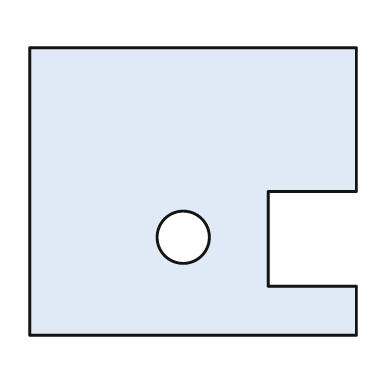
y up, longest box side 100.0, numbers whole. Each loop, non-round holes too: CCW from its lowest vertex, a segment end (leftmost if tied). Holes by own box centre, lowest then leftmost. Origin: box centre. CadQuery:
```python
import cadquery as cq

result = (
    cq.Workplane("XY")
    .moveTo(-50.0, -44.0)
    .lineTo(50.0, -44.0)
    .lineTo(50.0, -29.0)
    .lineTo(23.0, -29.0)
    .lineTo(23.0, 0.0)
    .lineTo(50.0, 0.0)
    .lineTo(50.0, 44.0)
    .lineTo(-50.0, 44.0)
    .close()
    .moveTo(-3.0, -14.0)
    .circle(8.0)
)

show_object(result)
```